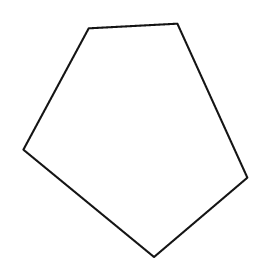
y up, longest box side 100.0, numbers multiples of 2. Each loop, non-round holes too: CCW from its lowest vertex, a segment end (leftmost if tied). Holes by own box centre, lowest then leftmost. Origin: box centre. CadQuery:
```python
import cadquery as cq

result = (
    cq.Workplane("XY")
    .moveTo(8.0, -50.0)
    .lineTo(48.0, -16.0)
    .lineTo(18.0, 50.0)
    .lineTo(-20.0, 48.0)
    .lineTo(-48.0, -4.0)
    .close()
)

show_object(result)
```